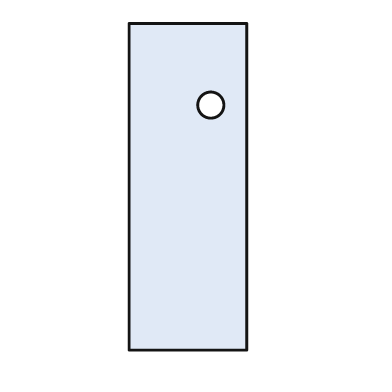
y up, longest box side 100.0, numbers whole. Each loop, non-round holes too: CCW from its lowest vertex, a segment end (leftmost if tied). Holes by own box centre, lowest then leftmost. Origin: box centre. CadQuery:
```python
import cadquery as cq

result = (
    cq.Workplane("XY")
    .moveTo(-18.0, -50.0)
    .lineTo(18.0, -50.0)
    .lineTo(18.0, 50.0)
    .lineTo(-18.0, 50.0)
    .close()
    .moveTo(7.0, 25.0)
    .circle(4.0)
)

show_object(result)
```